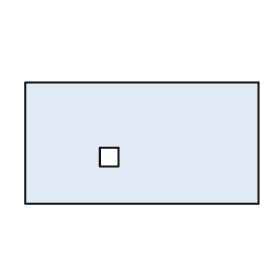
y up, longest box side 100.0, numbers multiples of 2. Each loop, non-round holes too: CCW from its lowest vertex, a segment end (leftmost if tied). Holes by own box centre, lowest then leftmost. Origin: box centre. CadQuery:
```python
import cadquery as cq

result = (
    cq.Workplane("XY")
    .moveTo(-50.0, -26.0)
    .lineTo(50.0, -26.0)
    .lineTo(50.0, 26.0)
    .lineTo(-50.0, 26.0)
    .close()
    .moveTo(-18.0, -10.0)
    .lineTo(-10.0, -10.0)
    .lineTo(-10.0, -2.0)
    .lineTo(-18.0, -2.0)
    .close()
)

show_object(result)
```